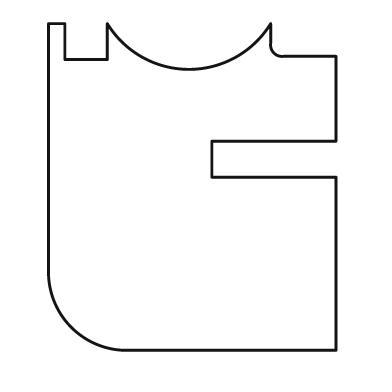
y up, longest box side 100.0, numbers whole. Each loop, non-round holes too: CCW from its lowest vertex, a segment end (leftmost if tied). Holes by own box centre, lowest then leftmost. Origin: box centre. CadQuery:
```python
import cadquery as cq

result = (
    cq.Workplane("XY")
    .moveTo(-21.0, -50.0)
    .lineTo(44.0, -50.0)
    .lineTo(44.0, 3.0)
    .lineTo(6.0, 3.0)
    .lineTo(6.0, 14.0)
    .lineTo(44.0, 14.0)
    .lineTo(44.0, 40.0)
    .lineTo(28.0, 40.0)
    .threePointArc((25.0, 41.0), (24.0, 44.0))
    .lineTo(24.0, 50.0)
    .threePointArc((-1.0, 36.0), (-26.0, 50.0))
    .lineTo(-26.0, 39.0)
    .lineTo(-39.0, 39.0)
    .lineTo(-39.0, 50.0)
    .lineTo(-44.0, 50.0)
    .lineTo(-44.0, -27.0)
    .threePointArc((-37.0, -43.0), (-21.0, -50.0))
    .close()
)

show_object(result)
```